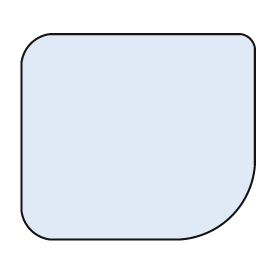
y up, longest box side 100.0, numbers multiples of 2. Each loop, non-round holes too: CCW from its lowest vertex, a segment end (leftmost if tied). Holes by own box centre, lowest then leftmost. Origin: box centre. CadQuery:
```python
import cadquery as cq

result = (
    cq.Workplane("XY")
    .moveTo(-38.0, -44.0)
    .lineTo(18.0, -44.0)
    .threePointArc((40.0, -34.0), (50.0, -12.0))
    .lineTo(50.0, 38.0)
    .threePointArc((48.0, 42.0), (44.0, 44.0))
    .lineTo(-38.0, 44.0)
    .threePointArc((-46.0, 40.0), (-50.0, 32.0))
    .lineTo(-50.0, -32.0)
    .threePointArc((-46.0, -40.0), (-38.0, -44.0))
    .close()
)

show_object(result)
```